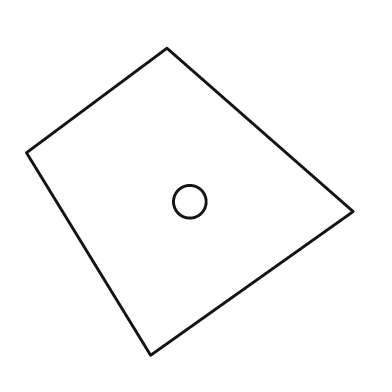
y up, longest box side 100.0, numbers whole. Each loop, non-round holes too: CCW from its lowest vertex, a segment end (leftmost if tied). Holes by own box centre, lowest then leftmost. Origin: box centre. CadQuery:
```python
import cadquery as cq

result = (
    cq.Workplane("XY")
    .moveTo(-12.0, -47.0)
    .lineTo(50.0, -3.0)
    .lineTo(-7.0, 47.0)
    .lineTo(-50.0, 15.0)
    .close()
    .moveTo(0.0, 0.0)
    .circle(5.0)
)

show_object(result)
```